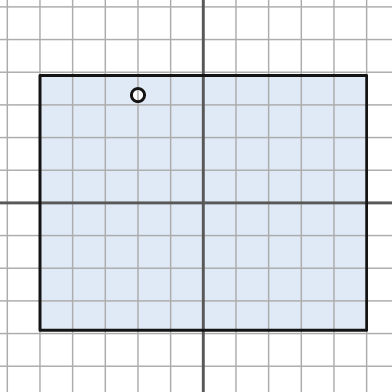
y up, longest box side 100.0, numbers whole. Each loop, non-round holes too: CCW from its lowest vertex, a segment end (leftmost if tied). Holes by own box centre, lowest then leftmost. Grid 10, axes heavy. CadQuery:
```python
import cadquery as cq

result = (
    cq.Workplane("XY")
    .moveTo(-50.0, -39.0)
    .lineTo(50.0, -39.0)
    .lineTo(50.0, 39.0)
    .lineTo(-50.0, 39.0)
    .close()
    .moveTo(-20.0, 33.0)
    .circle(2.0)
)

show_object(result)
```